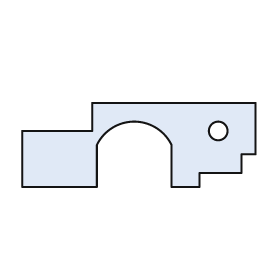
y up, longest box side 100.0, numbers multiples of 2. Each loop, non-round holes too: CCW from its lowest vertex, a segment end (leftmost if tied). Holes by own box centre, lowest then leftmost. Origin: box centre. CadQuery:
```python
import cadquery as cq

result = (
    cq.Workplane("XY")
    .moveTo(-50.0, -18.0)
    .lineTo(-18.0, -18.0)
    .lineTo(-18.0, 0.0)
    .threePointArc((-2.0, 10.0), (14.0, 0.0))
    .lineTo(14.0, -18.0)
    .lineTo(26.0, -18.0)
    .lineTo(26.0, -12.0)
    .lineTo(44.0, -12.0)
    .lineTo(44.0, -4.0)
    .lineTo(50.0, -4.0)
    .lineTo(50.0, 18.0)
    .lineTo(-20.0, 18.0)
    .lineTo(-20.0, 6.0)
    .lineTo(-50.0, 6.0)
    .close()
    .moveTo(34.0, 6.0)
    .circle(4.0)
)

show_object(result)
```